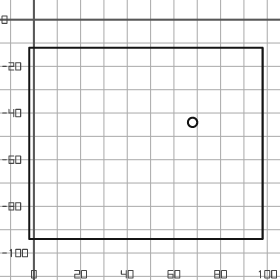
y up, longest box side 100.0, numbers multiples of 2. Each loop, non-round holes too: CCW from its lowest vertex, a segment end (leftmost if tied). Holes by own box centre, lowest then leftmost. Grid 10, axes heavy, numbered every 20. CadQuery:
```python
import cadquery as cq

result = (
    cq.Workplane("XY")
    .moveTo(-2.0, -94.0)
    .lineTo(98.0, -94.0)
    .lineTo(98.0, -12.0)
    .lineTo(-2.0, -12.0)
    .close()
    .moveTo(68.0, -44.0)
    .circle(2.0)
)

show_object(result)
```